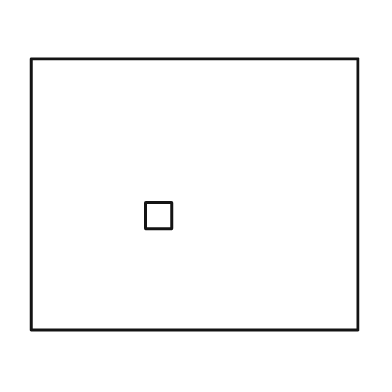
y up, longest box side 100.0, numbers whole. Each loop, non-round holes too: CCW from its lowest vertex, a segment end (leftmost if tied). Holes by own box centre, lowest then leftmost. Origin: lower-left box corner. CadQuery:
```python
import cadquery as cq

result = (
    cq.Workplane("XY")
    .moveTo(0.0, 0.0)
    .lineTo(100.0, 0.0)
    .lineTo(100.0, 83.0)
    .lineTo(0.0, 83.0)
    .close()
    .moveTo(35.0, 31.0)
    .lineTo(43.0, 31.0)
    .lineTo(43.0, 39.0)
    .lineTo(35.0, 39.0)
    .close()
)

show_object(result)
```